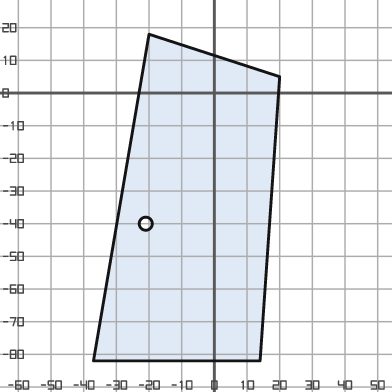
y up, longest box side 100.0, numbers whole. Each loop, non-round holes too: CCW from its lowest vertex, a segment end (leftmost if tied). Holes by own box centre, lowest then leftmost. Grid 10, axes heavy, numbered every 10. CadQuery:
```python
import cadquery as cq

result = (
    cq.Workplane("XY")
    .moveTo(-37.0, -82.0)
    .lineTo(14.0, -82.0)
    .lineTo(20.0, 5.0)
    .lineTo(-20.0, 18.0)
    .close()
    .moveTo(-21.0, -40.0)
    .circle(2.0)
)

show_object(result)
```